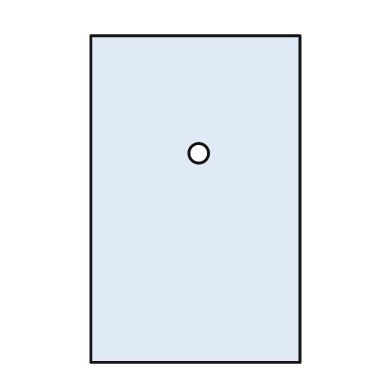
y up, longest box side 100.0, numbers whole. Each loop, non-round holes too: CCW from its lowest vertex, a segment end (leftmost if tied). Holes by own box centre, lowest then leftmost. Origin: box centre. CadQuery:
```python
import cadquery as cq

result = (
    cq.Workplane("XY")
    .moveTo(-32.0, -50.0)
    .lineTo(32.0, -50.0)
    .lineTo(32.0, 50.0)
    .lineTo(-32.0, 50.0)
    .close()
    .moveTo(1.0, 14.0)
    .circle(3.0)
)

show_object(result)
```